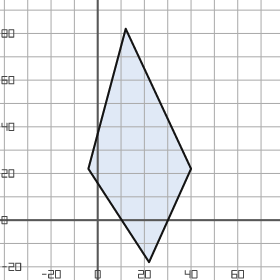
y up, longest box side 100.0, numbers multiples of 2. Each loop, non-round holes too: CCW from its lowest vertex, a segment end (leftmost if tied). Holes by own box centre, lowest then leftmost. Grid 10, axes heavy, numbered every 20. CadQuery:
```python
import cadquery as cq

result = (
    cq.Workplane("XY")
    .moveTo(22.0, -18.0)
    .lineTo(40.0, 22.0)
    .lineTo(12.0, 82.0)
    .lineTo(-4.0, 22.0)
    .close()
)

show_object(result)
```